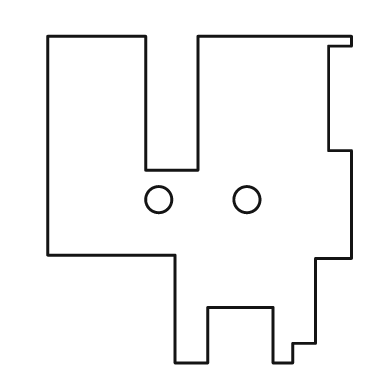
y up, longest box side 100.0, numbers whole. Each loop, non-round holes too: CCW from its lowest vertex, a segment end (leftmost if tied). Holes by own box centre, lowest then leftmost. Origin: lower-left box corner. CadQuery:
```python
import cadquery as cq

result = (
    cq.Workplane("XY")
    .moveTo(39.0, 0.0)
    .lineTo(49.0, 0.0)
    .lineTo(49.0, 17.0)
    .lineTo(69.0, 17.0)
    .lineTo(69.0, 0.0)
    .lineTo(75.0, 0.0)
    .lineTo(75.0, 6.0)
    .lineTo(82.0, 6.0)
    .lineTo(82.0, 32.0)
    .lineTo(93.0, 32.0)
    .lineTo(93.0, 65.0)
    .lineTo(86.0, 65.0)
    .lineTo(86.0, 97.0)
    .lineTo(93.0, 97.0)
    .lineTo(93.0, 100.0)
    .lineTo(46.0, 100.0)
    .lineTo(46.0, 59.0)
    .lineTo(30.0, 59.0)
    .lineTo(30.0, 100.0)
    .lineTo(0.0, 100.0)
    .lineTo(0.0, 33.0)
    .lineTo(39.0, 33.0)
    .close()
    .moveTo(34.0, 50.0)
    .circle(4.0)
    .moveTo(61.0, 50.0)
    .circle(4.0)
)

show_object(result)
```